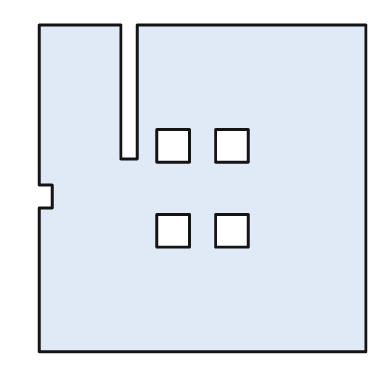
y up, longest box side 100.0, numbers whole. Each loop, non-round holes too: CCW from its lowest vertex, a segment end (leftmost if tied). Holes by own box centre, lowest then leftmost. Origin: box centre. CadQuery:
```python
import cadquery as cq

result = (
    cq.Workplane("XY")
    .moveTo(-50.0, -50.0)
    .lineTo(50.0, -50.0)
    .lineTo(50.0, 50.0)
    .lineTo(-20.0, 50.0)
    .lineTo(-20.0, 9.0)
    .lineTo(-25.0, 9.0)
    .lineTo(-25.0, 50.0)
    .lineTo(-50.0, 50.0)
    .lineTo(-50.0, 1.0)
    .lineTo(-46.0, 1.0)
    .lineTo(-46.0, -6.0)
    .lineTo(-50.0, -6.0)
    .close()
    .moveTo(-14.0, -18.0)
    .lineTo(-4.0, -18.0)
    .lineTo(-4.0, -8.0)
    .lineTo(-14.0, -8.0)
    .close()
    .moveTo(4.0, -18.0)
    .lineTo(14.0, -18.0)
    .lineTo(14.0, -8.0)
    .lineTo(4.0, -8.0)
    .close()
    .moveTo(-14.0, 8.0)
    .lineTo(-4.0, 8.0)
    .lineTo(-4.0, 18.0)
    .lineTo(-14.0, 18.0)
    .close()
    .moveTo(4.0, 8.0)
    .lineTo(14.0, 8.0)
    .lineTo(14.0, 18.0)
    .lineTo(4.0, 18.0)
    .close()
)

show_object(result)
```